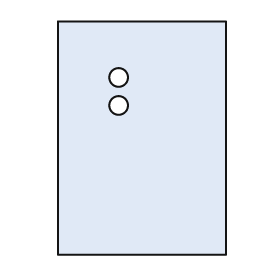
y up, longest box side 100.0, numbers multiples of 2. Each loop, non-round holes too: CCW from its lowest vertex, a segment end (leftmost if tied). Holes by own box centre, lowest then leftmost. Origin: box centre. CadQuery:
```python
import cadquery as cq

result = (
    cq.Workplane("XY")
    .moveTo(-36.0, -50.0)
    .lineTo(36.0, -50.0)
    .lineTo(36.0, 50.0)
    .lineTo(-36.0, 50.0)
    .close()
    .moveTo(-10.0, 14.0)
    .circle(4.0)
    .moveTo(-10.0, 26.0)
    .circle(4.0)
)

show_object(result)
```